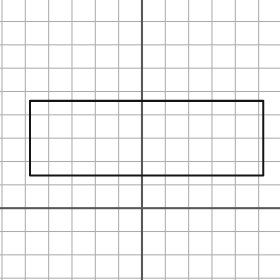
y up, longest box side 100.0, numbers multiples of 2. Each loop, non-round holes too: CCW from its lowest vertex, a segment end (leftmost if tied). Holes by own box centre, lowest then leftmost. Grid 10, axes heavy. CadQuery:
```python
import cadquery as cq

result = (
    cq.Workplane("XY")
    .moveTo(-48.0, 14.0)
    .lineTo(52.0, 14.0)
    .lineTo(52.0, 46.0)
    .lineTo(-48.0, 46.0)
    .close()
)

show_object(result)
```